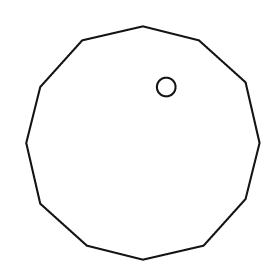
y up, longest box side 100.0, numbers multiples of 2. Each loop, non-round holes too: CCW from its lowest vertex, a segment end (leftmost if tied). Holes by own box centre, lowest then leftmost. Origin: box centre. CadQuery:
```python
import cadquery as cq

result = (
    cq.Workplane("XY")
    .moveTo(0.0, -50.0)
    .lineTo(26.0, -44.0)
    .lineTo(44.0, -24.0)
    .lineTo(50.0, 0.0)
    .lineTo(44.0, 26.0)
    .lineTo(24.0, 44.0)
    .lineTo(0.0, 50.0)
    .lineTo(-26.0, 44.0)
    .lineTo(-44.0, 24.0)
    .lineTo(-50.0, 0.0)
    .lineTo(-44.0, -26.0)
    .lineTo(-24.0, -44.0)
    .close()
    .moveTo(10.0, 24.0)
    .circle(4.0)
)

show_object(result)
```